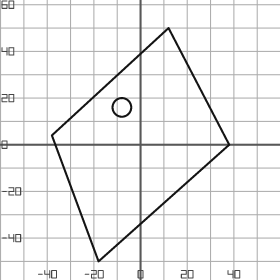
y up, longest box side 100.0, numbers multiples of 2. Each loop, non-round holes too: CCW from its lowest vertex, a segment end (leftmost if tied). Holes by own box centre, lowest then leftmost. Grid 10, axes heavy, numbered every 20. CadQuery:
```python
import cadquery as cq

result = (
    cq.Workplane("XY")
    .moveTo(-18.0, -50.0)
    .lineTo(38.0, 0.0)
    .lineTo(12.0, 50.0)
    .lineTo(-38.0, 4.0)
    .close()
    .moveTo(-8.0, 16.0)
    .circle(4.0)
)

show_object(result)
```